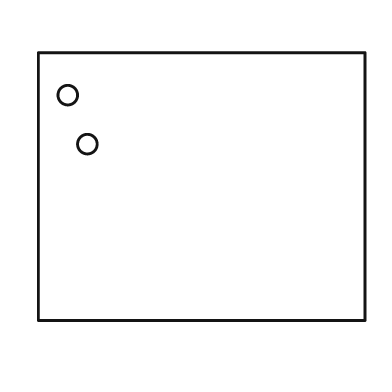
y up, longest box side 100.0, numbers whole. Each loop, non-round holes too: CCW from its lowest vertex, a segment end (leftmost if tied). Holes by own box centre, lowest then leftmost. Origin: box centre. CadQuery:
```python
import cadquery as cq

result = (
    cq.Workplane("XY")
    .moveTo(-50.0, -41.0)
    .lineTo(50.0, -41.0)
    .lineTo(50.0, 41.0)
    .lineTo(-50.0, 41.0)
    .close()
    .moveTo(-35.0, 13.0)
    .circle(3.0)
    .moveTo(-41.0, 28.0)
    .circle(3.0)
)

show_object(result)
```